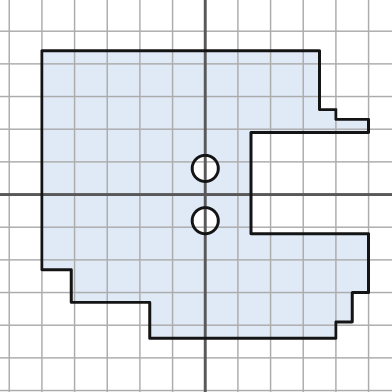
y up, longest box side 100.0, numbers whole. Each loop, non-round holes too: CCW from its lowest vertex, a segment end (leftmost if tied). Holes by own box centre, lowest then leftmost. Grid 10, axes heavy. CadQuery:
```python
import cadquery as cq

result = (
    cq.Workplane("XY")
    .moveTo(-17.0, -44.0)
    .lineTo(40.0, -44.0)
    .lineTo(40.0, -39.0)
    .lineTo(45.0, -39.0)
    .lineTo(45.0, -30.0)
    .lineTo(50.0, -30.0)
    .lineTo(50.0, -12.0)
    .lineTo(14.0, -12.0)
    .lineTo(14.0, 19.0)
    .lineTo(50.0, 19.0)
    .lineTo(50.0, 23.0)
    .lineTo(40.0, 23.0)
    .lineTo(40.0, 26.0)
    .lineTo(35.0, 26.0)
    .lineTo(35.0, 44.0)
    .lineTo(-50.0, 44.0)
    .lineTo(-50.0, -23.0)
    .lineTo(-41.0, -23.0)
    .lineTo(-41.0, -33.0)
    .lineTo(-17.0, -33.0)
    .close()
    .moveTo(0.0, -8.0)
    .circle(4.0)
    .moveTo(0.0, 8.0)
    .circle(4.0)
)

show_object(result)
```